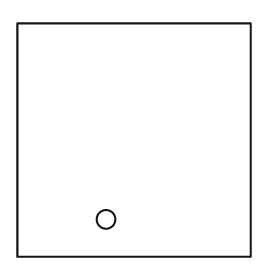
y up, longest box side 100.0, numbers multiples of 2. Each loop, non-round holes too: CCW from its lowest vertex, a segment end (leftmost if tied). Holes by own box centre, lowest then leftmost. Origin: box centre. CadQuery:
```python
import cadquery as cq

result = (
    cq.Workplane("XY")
    .moveTo(-50.0, -50.0)
    .lineTo(50.0, -50.0)
    .lineTo(50.0, 50.0)
    .lineTo(-50.0, 50.0)
    .close()
    .moveTo(-12.0, -34.0)
    .circle(4.0)
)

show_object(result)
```